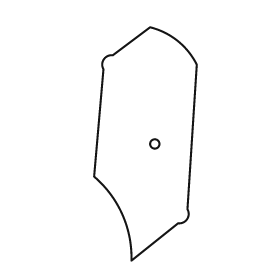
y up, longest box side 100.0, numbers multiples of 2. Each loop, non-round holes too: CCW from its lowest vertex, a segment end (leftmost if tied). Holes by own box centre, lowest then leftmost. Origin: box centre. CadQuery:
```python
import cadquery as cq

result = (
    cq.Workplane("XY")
    .moveTo(-6.0, -50.0)
    .lineTo(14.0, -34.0)
    .threePointArc((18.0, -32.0), (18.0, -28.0))
    .lineTo(22.0, 34.0)
    .threePointArc((14.0, 44.0), (2.0, 50.0))
    .lineTo(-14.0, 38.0)
    .threePointArc((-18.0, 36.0), (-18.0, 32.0))
    .lineTo(-22.0, -14.0)
    .threePointArc((-10.0, -30.0), (-6.0, -50.0))
    .close()
    .moveTo(4.0, 0.0)
    .circle(2.0)
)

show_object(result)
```